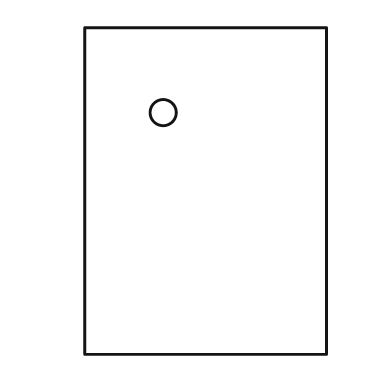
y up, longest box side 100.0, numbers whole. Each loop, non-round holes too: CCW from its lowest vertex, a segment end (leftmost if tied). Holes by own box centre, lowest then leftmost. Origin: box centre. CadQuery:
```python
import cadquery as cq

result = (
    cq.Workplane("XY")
    .moveTo(-37.0, -50.0)
    .lineTo(37.0, -50.0)
    .lineTo(37.0, 50.0)
    .lineTo(-37.0, 50.0)
    .close()
    .moveTo(-13.0, 24.0)
    .circle(4.0)
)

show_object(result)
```